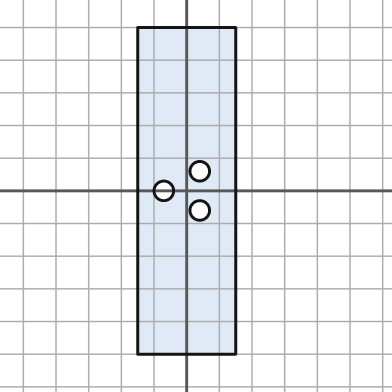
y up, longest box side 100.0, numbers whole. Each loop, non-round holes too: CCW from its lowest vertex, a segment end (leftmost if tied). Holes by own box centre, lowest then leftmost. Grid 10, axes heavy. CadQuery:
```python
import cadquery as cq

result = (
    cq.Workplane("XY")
    .moveTo(-15.0, -50.0)
    .lineTo(15.0, -50.0)
    .lineTo(15.0, 50.0)
    .lineTo(-15.0, 50.0)
    .close()
    .moveTo(4.0, -6.0)
    .circle(3.0)
    .moveTo(-7.0, 0.0)
    .circle(3.0)
    .moveTo(4.0, 6.0)
    .circle(3.0)
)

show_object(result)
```